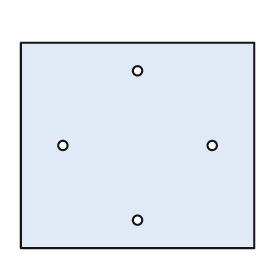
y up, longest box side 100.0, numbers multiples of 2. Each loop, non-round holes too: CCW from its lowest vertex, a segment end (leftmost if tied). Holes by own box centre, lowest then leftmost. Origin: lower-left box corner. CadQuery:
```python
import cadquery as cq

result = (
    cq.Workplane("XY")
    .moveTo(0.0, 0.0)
    .lineTo(100.0, 0.0)
    .lineTo(100.0, 88.0)
    .lineTo(0.0, 88.0)
    .close()
    .moveTo(50.0, 12.0)
    .circle(2.0)
    .moveTo(18.0, 44.0)
    .circle(2.0)
    .moveTo(82.0, 44.0)
    .circle(2.0)
    .moveTo(50.0, 76.0)
    .circle(2.0)
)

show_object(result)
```